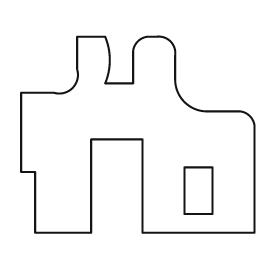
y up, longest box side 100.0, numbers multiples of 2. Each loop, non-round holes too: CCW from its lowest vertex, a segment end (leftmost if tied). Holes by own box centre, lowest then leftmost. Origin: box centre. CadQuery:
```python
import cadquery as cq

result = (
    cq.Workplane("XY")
    .moveTo(-44.0, -42.0)
    .lineTo(-20.0, -42.0)
    .lineTo(-20.0, -2.0)
    .lineTo(2.0, -2.0)
    .lineTo(2.0, -42.0)
    .lineTo(50.0, -42.0)
    .lineTo(50.0, 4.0)
    .threePointArc((48.0, 8.0), (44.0, 10.0))
    .lineTo(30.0, 10.0)
    .threePointArc((20.0, 14.0), (16.0, 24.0))
    .lineTo(16.0, 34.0)
    .threePointArc((14.0, 40.0), (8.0, 42.0))
    .lineTo(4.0, 42.0)
    .threePointArc((0.0, 40.0), (-2.0, 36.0))
    .lineTo(-2.0, 22.0)
    .lineTo(-14.0, 22.0)
    .threePointArc((-12.0, 32.0), (-14.0, 42.0))
    .lineTo(-26.0, 42.0)
    .lineTo(-26.0, 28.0)
    .threePointArc((-28.0, 20.0), (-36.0, 18.0))
    .lineTo(-50.0, 18.0)
    .lineTo(-50.0, -16.0)
    .lineTo(-44.0, -16.0)
    .close()
    .moveTo(20.0, -34.0)
    .lineTo(32.0, -34.0)
    .lineTo(32.0, -14.0)
    .lineTo(20.0, -14.0)
    .close()
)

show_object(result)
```